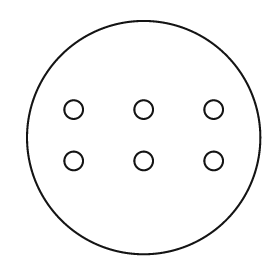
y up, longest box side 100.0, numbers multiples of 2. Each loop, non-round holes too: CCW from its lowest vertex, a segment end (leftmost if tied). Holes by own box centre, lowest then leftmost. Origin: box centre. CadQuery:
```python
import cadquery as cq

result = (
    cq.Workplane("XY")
    .moveTo(0.0, 0.0)
    .circle(50.0)
    .moveTo(-30.0, -10.0)
    .circle(4.0)
    .moveTo(0.0, -10.0)
    .circle(4.0)
    .moveTo(30.0, -10.0)
    .circle(4.0)
    .moveTo(-30.0, 12.0)
    .circle(4.0)
    .moveTo(0.0, 12.0)
    .circle(4.0)
    .moveTo(30.0, 12.0)
    .circle(4.0)
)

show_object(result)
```